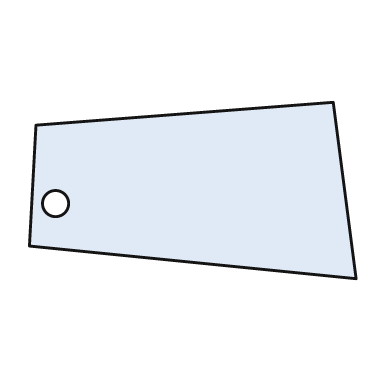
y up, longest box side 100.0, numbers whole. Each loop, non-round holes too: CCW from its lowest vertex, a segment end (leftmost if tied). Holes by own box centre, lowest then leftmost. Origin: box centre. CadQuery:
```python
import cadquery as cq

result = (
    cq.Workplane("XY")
    .moveTo(50.0, -27.0)
    .lineTo(43.0, 27.0)
    .lineTo(-48.0, 20.0)
    .lineTo(-50.0, -17.0)
    .close()
    .moveTo(-42.0, -4.0)
    .circle(4.0)
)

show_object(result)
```